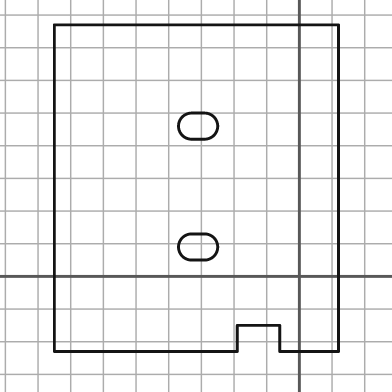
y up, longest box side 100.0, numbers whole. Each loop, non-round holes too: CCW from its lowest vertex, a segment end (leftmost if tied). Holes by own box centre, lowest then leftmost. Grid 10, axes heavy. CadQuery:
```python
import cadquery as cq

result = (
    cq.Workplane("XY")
    .moveTo(-75.0, -23.0)
    .lineTo(-19.0, -23.0)
    .lineTo(-19.0, -15.0)
    .lineTo(-6.0, -15.0)
    .lineTo(-6.0, -23.0)
    .lineTo(12.0, -23.0)
    .lineTo(12.0, 77.0)
    .lineTo(-75.0, 77.0)
    .close()
    .moveTo(-33.0, 5.0)
    .lineTo(-29.0, 5.0)
    .threePointArc((-25.0, 9.0), (-29.0, 13.0))
    .lineTo(-33.0, 13.0)
    .threePointArc((-37.0, 9.0), (-33.0, 5.0))
    .close()
    .moveTo(-33.0, 42.0)
    .lineTo(-29.0, 42.0)
    .threePointArc((-25.0, 46.0), (-29.0, 50.0))
    .lineTo(-33.0, 50.0)
    .threePointArc((-37.0, 46.0), (-33.0, 42.0))
    .close()
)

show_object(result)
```